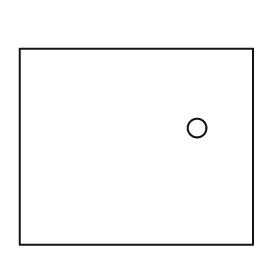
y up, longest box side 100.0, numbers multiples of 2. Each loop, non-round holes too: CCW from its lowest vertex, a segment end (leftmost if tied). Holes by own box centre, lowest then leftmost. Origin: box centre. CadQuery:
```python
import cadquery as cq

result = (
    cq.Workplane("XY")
    .moveTo(-50.0, -42.0)
    .lineTo(50.0, -42.0)
    .lineTo(50.0, 42.0)
    .lineTo(-50.0, 42.0)
    .close()
    .moveTo(26.0, 8.0)
    .circle(4.0)
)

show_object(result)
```